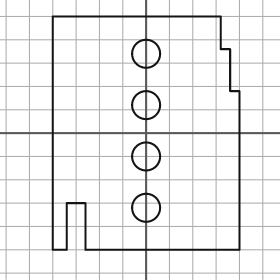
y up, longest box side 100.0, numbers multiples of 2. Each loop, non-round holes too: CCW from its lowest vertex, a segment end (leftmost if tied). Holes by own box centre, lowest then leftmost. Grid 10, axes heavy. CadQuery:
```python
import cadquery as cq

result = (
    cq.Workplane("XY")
    .moveTo(-40.0, -50.0)
    .lineTo(-34.0, -50.0)
    .lineTo(-34.0, -30.0)
    .lineTo(-26.0, -30.0)
    .lineTo(-26.0, -50.0)
    .lineTo(40.0, -50.0)
    .lineTo(40.0, 18.0)
    .lineTo(36.0, 18.0)
    .lineTo(36.0, 36.0)
    .lineTo(32.0, 36.0)
    .lineTo(32.0, 50.0)
    .lineTo(-40.0, 50.0)
    .close()
    .moveTo(0.0, -32.0)
    .circle(6.0)
    .moveTo(0.0, -10.0)
    .circle(6.0)
    .moveTo(0.0, 12.0)
    .circle(6.0)
    .moveTo(0.0, 34.0)
    .circle(6.0)
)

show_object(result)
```